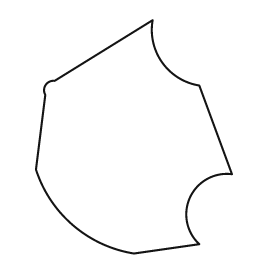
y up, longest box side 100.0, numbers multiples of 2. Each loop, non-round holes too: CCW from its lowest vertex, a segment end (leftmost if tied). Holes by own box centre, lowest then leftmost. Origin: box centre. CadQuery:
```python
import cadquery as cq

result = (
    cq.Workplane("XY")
    .moveTo(0.0, -50.0)
    .lineTo(28.0, -46.0)
    .threePointArc((24.0, -26.0), (42.0, -16.0))
    .lineTo(28.0, 22.0)
    .threePointArc((12.0, 32.0), (8.0, 50.0))
    .lineTo(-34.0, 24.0)
    .threePointArc((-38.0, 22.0), (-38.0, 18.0))
    .lineTo(-42.0, -14.0)
    .threePointArc((-26.0, -38.0), (0.0, -50.0))
    .close()
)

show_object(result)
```